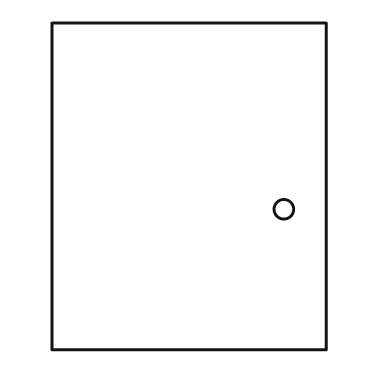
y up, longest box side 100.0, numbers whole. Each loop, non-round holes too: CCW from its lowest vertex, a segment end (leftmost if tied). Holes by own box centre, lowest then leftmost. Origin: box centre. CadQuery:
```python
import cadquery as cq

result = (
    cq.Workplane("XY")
    .moveTo(-42.0, -50.0)
    .lineTo(42.0, -50.0)
    .lineTo(42.0, 50.0)
    .lineTo(-42.0, 50.0)
    .close()
    .moveTo(29.0, -7.0)
    .circle(3.0)
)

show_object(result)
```